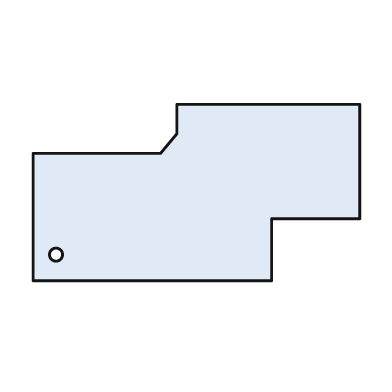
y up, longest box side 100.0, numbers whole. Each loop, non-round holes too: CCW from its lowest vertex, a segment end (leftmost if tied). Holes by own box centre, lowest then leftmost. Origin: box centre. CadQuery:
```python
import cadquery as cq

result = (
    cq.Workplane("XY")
    .moveTo(-50.0, -27.0)
    .lineTo(23.0, -27.0)
    .lineTo(23.0, -8.0)
    .lineTo(50.0, -8.0)
    .lineTo(50.0, 27.0)
    .lineTo(-6.0, 27.0)
    .lineTo(-6.0, 18.0)
    .lineTo(-11.0, 12.0)
    .lineTo(-50.0, 12.0)
    .close()
    .moveTo(-43.0, -19.0)
    .circle(2.0)
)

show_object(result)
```